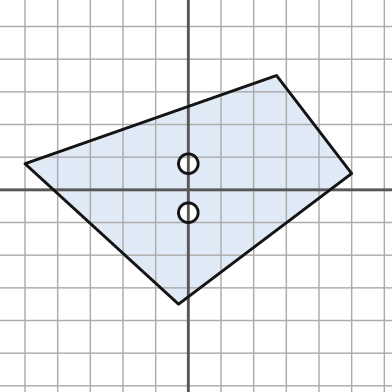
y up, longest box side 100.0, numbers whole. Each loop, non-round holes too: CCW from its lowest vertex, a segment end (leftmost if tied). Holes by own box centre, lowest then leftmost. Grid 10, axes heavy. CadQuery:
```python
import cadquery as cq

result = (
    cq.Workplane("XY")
    .moveTo(-3.0, -35.0)
    .lineTo(50.0, 5.0)
    .lineTo(27.0, 35.0)
    .lineTo(-50.0, 8.0)
    .close()
    .moveTo(0.0, -7.0)
    .circle(3.0)
    .moveTo(0.0, 8.0)
    .circle(3.0)
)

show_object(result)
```